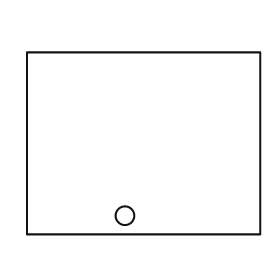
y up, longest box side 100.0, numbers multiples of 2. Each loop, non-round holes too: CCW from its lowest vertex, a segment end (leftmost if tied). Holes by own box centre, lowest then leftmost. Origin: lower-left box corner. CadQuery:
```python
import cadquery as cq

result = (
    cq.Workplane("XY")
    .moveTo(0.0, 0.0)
    .lineTo(100.0, 0.0)
    .lineTo(100.0, 78.0)
    .lineTo(0.0, 78.0)
    .close()
    .moveTo(42.0, 8.0)
    .circle(4.0)
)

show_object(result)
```